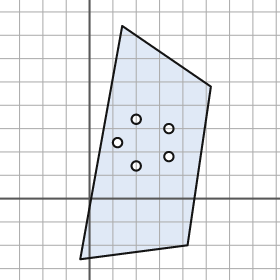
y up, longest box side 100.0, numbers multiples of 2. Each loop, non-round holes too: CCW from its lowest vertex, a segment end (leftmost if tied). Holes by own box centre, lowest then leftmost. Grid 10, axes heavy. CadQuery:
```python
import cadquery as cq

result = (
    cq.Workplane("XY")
    .moveTo(-4.0, -26.0)
    .lineTo(42.0, -20.0)
    .lineTo(52.0, 48.0)
    .lineTo(14.0, 74.0)
    .close()
    .moveTo(20.0, 14.0)
    .circle(2.0)
    .moveTo(34.0, 18.0)
    .circle(2.0)
    .moveTo(12.0, 24.0)
    .circle(2.0)
    .moveTo(34.0, 30.0)
    .circle(2.0)
    .moveTo(20.0, 34.0)
    .circle(2.0)
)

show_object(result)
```